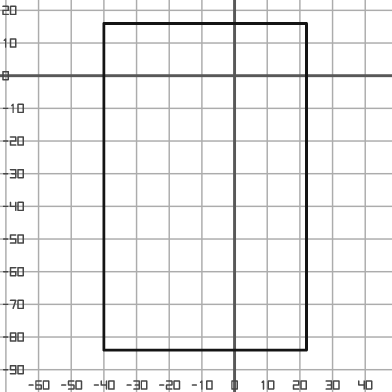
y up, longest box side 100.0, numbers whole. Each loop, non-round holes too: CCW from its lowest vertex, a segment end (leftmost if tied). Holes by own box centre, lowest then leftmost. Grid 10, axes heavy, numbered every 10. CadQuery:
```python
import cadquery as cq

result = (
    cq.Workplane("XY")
    .moveTo(-40.0, -84.0)
    .lineTo(22.0, -84.0)
    .lineTo(22.0, 16.0)
    .lineTo(-40.0, 16.0)
    .close()
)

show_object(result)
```